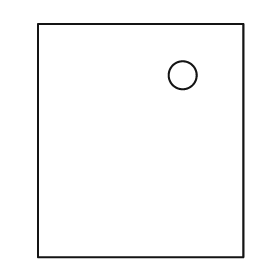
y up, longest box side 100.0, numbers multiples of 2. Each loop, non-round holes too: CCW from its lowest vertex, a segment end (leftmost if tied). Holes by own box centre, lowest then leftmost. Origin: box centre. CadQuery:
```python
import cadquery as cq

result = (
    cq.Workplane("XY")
    .moveTo(-44.0, -50.0)
    .lineTo(44.0, -50.0)
    .lineTo(44.0, 50.0)
    .lineTo(-44.0, 50.0)
    .close()
    .moveTo(18.0, 28.0)
    .circle(6.0)
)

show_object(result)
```